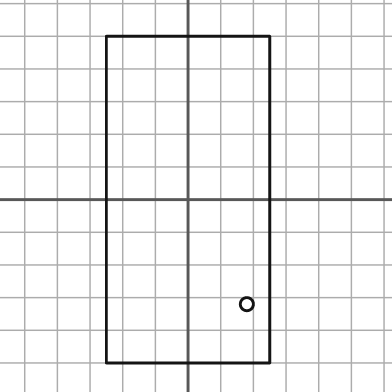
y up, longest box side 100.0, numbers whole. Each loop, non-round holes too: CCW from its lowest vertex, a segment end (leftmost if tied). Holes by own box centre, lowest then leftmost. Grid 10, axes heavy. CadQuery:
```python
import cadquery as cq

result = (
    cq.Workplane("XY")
    .moveTo(-25.0, -50.0)
    .lineTo(25.0, -50.0)
    .lineTo(25.0, 50.0)
    .lineTo(-25.0, 50.0)
    .close()
    .moveTo(18.0, -32.0)
    .circle(2.0)
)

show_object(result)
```